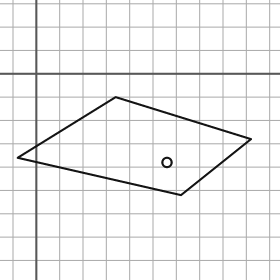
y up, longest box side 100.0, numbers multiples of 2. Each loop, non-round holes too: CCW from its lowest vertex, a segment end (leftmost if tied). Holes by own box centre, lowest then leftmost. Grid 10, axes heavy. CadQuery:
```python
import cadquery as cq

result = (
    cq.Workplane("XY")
    .moveTo(62.0, -52.0)
    .lineTo(92.0, -28.0)
    .lineTo(34.0, -10.0)
    .lineTo(-8.0, -36.0)
    .close()
    .moveTo(56.0, -38.0)
    .circle(2.0)
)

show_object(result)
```